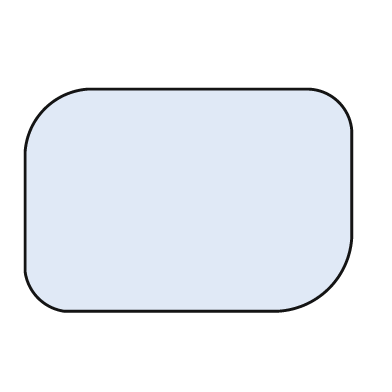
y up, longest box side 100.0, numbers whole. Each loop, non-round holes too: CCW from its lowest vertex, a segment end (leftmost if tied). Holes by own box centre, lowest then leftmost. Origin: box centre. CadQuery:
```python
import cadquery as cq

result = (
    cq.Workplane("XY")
    .moveTo(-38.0, -34.0)
    .lineTo(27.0, -34.0)
    .threePointArc((43.0, -27.0), (50.0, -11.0))
    .lineTo(50.0, 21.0)
    .threePointArc((46.0, 30.0), (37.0, 34.0))
    .lineTo(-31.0, 34.0)
    .threePointArc((-44.0, 28.0), (-50.0, 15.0))
    .lineTo(-50.0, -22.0)
    .threePointArc((-46.0, -30.0), (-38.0, -34.0))
    .close()
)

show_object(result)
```